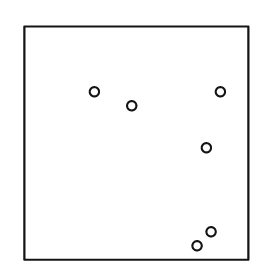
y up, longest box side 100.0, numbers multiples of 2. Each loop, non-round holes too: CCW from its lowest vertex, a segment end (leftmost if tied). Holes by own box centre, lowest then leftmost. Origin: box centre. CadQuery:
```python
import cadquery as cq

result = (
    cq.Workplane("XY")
    .moveTo(-48.0, -50.0)
    .lineTo(48.0, -50.0)
    .lineTo(48.0, 50.0)
    .lineTo(-48.0, 50.0)
    .close()
    .moveTo(26.0, -44.0)
    .circle(2.0)
    .moveTo(32.0, -38.0)
    .circle(2.0)
    .moveTo(30.0, -2.0)
    .circle(2.0)
    .moveTo(-2.0, 16.0)
    .circle(2.0)
    .moveTo(-18.0, 22.0)
    .circle(2.0)
    .moveTo(36.0, 22.0)
    .circle(2.0)
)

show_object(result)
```